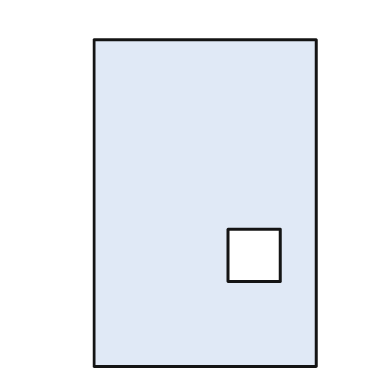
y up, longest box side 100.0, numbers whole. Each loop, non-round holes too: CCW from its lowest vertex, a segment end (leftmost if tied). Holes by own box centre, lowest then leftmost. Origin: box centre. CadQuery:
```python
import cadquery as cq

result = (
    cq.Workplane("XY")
    .moveTo(-34.0, -50.0)
    .lineTo(34.0, -50.0)
    .lineTo(34.0, 50.0)
    .lineTo(-34.0, 50.0)
    .close()
    .moveTo(7.0, -24.0)
    .lineTo(23.0, -24.0)
    .lineTo(23.0, -8.0)
    .lineTo(7.0, -8.0)
    .close()
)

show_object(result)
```